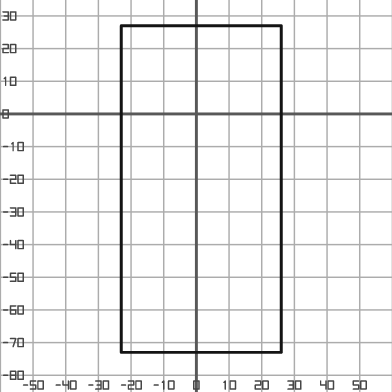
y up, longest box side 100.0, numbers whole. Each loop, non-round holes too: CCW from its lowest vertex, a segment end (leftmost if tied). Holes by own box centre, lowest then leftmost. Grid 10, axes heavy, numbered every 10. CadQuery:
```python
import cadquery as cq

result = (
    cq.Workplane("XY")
    .moveTo(-23.0, -73.0)
    .lineTo(26.0, -73.0)
    .lineTo(26.0, 27.0)
    .lineTo(-23.0, 27.0)
    .close()
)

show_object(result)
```